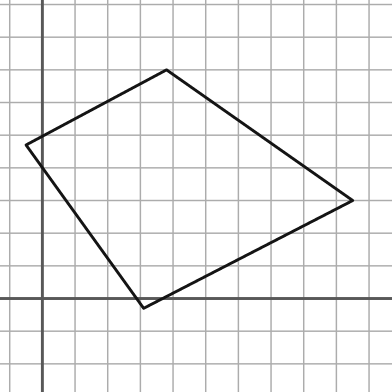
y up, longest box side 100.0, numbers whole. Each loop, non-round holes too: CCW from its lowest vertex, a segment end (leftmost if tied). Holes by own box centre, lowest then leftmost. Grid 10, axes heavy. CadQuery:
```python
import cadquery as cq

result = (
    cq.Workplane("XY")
    .moveTo(31.0, -3.0)
    .lineTo(95.0, 30.0)
    .lineTo(38.0, 70.0)
    .lineTo(-5.0, 47.0)
    .close()
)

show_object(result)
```